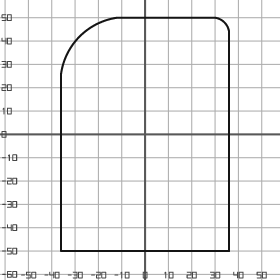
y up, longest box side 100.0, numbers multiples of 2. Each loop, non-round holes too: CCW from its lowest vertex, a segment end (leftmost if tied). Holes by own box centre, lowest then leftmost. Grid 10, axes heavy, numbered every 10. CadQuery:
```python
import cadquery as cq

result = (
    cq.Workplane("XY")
    .moveTo(-36.0, -50.0)
    .lineTo(36.0, -50.0)
    .lineTo(36.0, 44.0)
    .threePointArc((34.0, 48.0), (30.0, 50.0))
    .lineTo(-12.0, 50.0)
    .threePointArc((-28.0, 42.0), (-36.0, 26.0))
    .close()
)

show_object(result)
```